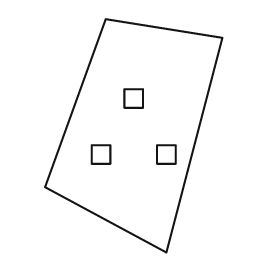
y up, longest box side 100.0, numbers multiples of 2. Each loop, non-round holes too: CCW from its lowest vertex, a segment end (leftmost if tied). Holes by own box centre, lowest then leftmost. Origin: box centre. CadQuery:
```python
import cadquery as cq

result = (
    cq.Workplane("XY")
    .moveTo(14.0, -50.0)
    .lineTo(38.0, 42.0)
    .lineTo(-12.0, 50.0)
    .lineTo(-38.0, -22.0)
    .close()
    .moveTo(-18.0, -12.0)
    .lineTo(-10.0, -12.0)
    .lineTo(-10.0, -4.0)
    .lineTo(-18.0, -4.0)
    .close()
    .moveTo(10.0, -12.0)
    .lineTo(18.0, -12.0)
    .lineTo(18.0, -4.0)
    .lineTo(10.0, -4.0)
    .close()
    .moveTo(-4.0, 12.0)
    .lineTo(4.0, 12.0)
    .lineTo(4.0, 20.0)
    .lineTo(-4.0, 20.0)
    .close()
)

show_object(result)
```